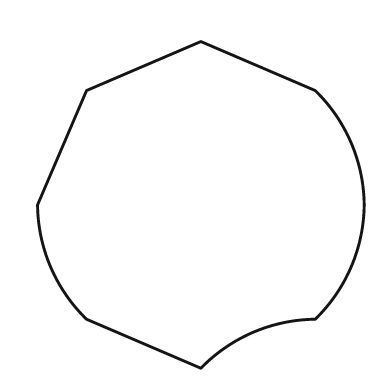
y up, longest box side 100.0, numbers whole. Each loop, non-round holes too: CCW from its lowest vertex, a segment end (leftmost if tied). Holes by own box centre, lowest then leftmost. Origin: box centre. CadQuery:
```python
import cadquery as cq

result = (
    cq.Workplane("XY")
    .moveTo(0.0, -50.0)
    .threePointArc((16.0, -39.0), (35.0, -35.0))
    .threePointArc((46.0, -19.0), (50.0, 0.0))
    .threePointArc((46.0, 19.0), (35.0, 35.0))
    .lineTo(0.0, 50.0)
    .lineTo(-35.0, 35.0)
    .lineTo(-50.0, 0.0)
    .threePointArc((-46.0, -19.0), (-35.0, -35.0))
    .close()
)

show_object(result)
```